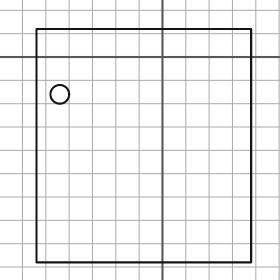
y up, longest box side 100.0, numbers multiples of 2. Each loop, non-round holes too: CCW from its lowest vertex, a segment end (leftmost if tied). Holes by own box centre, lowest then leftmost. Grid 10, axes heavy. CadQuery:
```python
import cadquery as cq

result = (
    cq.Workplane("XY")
    .moveTo(-54.0, -88.0)
    .lineTo(38.0, -88.0)
    .lineTo(38.0, 12.0)
    .lineTo(-54.0, 12.0)
    .close()
    .moveTo(-44.0, -16.0)
    .circle(4.0)
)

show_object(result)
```